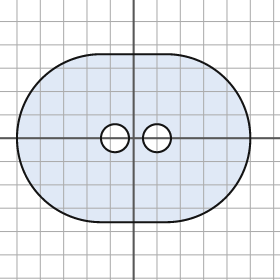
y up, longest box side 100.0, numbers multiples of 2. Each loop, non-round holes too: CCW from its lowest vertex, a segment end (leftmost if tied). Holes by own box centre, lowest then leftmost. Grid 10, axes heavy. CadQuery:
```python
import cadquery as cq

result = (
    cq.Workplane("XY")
    .moveTo(-14.0, -36.0)
    .lineTo(14.0, -36.0)
    .threePointArc((50.0, 0.0), (14.0, 36.0))
    .lineTo(-14.0, 36.0)
    .threePointArc((-50.0, 0.0), (-14.0, -36.0))
    .close()
    .moveTo(-8.0, 0.0)
    .circle(6.0)
    .moveTo(10.0, 0.0)
    .circle(6.0)
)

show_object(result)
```